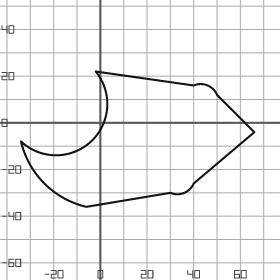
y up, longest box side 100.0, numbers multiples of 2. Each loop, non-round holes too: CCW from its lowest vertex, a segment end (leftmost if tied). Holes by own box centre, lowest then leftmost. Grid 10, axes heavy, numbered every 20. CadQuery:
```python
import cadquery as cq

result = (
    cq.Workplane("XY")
    .moveTo(-6.0, -36.0)
    .lineTo(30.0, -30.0)
    .threePointArc((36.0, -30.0), (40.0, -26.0))
    .lineTo(66.0, -4.0)
    .lineTo(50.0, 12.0)
    .threePointArc((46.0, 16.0), (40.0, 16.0))
    .lineTo(-2.0, 22.0)
    .threePointArc((-4.0, -8.0), (-34.0, -8.0))
    .threePointArc((-24.0, -26.0), (-6.0, -36.0))
    .close()
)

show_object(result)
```